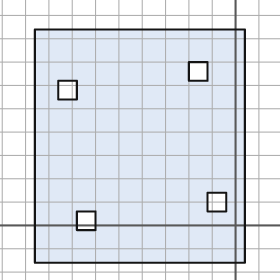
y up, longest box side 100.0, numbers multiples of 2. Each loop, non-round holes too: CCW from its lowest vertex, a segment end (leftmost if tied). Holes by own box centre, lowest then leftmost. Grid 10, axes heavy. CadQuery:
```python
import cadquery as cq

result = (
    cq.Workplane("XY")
    .moveTo(-86.0, -16.0)
    .lineTo(4.0, -16.0)
    .lineTo(4.0, 84.0)
    .lineTo(-86.0, 84.0)
    .close()
    .moveTo(-68.0, -2.0)
    .lineTo(-60.0, -2.0)
    .lineTo(-60.0, 6.0)
    .lineTo(-68.0, 6.0)
    .close()
    .moveTo(-12.0, 6.0)
    .lineTo(-4.0, 6.0)
    .lineTo(-4.0, 14.0)
    .lineTo(-12.0, 14.0)
    .close()
    .moveTo(-76.0, 54.0)
    .lineTo(-68.0, 54.0)
    .lineTo(-68.0, 62.0)
    .lineTo(-76.0, 62.0)
    .close()
    .moveTo(-20.0, 62.0)
    .lineTo(-12.0, 62.0)
    .lineTo(-12.0, 70.0)
    .lineTo(-20.0, 70.0)
    .close()
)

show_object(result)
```